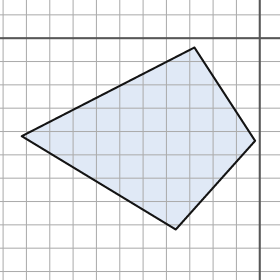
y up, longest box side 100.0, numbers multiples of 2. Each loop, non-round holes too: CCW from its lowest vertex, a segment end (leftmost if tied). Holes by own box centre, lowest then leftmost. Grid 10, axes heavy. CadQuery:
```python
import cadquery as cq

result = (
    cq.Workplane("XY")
    .moveTo(-36.0, -82.0)
    .lineTo(-2.0, -44.0)
    .lineTo(-28.0, -4.0)
    .lineTo(-102.0, -42.0)
    .close()
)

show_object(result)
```